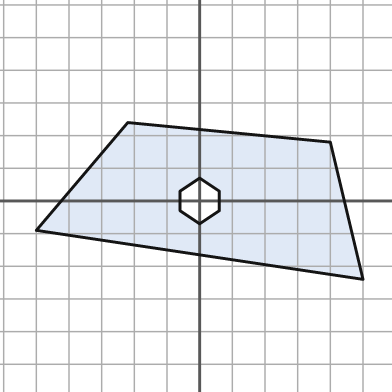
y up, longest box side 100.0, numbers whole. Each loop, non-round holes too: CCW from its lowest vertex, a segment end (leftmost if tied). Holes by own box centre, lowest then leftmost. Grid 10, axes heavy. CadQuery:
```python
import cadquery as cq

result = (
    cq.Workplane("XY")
    .moveTo(50.0, -24.0)
    .lineTo(40.0, 18.0)
    .lineTo(-22.0, 24.0)
    .lineTo(-50.0, -9.0)
    .close()
    .moveTo(0.0, -7.0)
    .lineTo(6.0, -3.0)
    .lineTo(6.0, 3.0)
    .lineTo(0.0, 7.0)
    .lineTo(-6.0, 3.0)
    .lineTo(-6.0, -3.0)
    .close()
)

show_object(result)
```